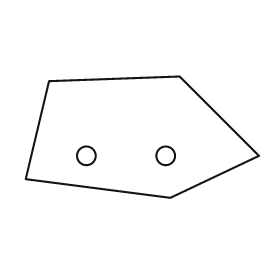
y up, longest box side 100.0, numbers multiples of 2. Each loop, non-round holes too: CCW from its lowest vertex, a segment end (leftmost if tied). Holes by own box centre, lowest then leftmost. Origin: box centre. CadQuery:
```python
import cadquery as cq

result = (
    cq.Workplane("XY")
    .moveTo(12.0, -26.0)
    .lineTo(50.0, -8.0)
    .lineTo(16.0, 26.0)
    .lineTo(-40.0, 24.0)
    .lineTo(-50.0, -18.0)
    .close()
    .moveTo(-24.0, -8.0)
    .circle(4.0)
    .moveTo(10.0, -8.0)
    .circle(4.0)
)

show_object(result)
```